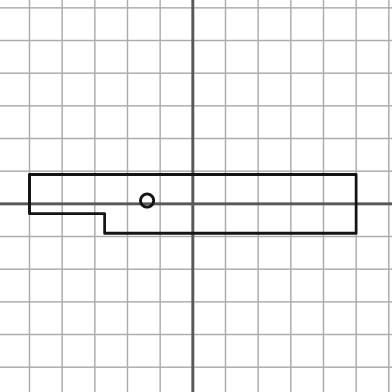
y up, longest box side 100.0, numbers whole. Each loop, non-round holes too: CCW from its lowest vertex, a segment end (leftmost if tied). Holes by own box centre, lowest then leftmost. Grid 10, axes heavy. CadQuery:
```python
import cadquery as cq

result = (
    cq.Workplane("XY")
    .moveTo(-27.0, -9.0)
    .lineTo(50.0, -9.0)
    .lineTo(50.0, 9.0)
    .lineTo(-50.0, 9.0)
    .lineTo(-50.0, -3.0)
    .lineTo(-27.0, -3.0)
    .close()
    .moveTo(-14.0, 1.0)
    .circle(2.0)
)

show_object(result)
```